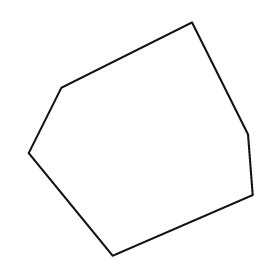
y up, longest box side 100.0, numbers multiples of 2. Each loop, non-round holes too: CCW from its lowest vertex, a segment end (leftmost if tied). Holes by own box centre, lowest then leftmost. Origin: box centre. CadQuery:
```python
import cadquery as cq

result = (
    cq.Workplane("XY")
    .moveTo(-12.0, -50.0)
    .lineTo(48.0, -24.0)
    .lineTo(46.0, 2.0)
    .lineTo(22.0, 50.0)
    .lineTo(-34.0, 22.0)
    .lineTo(-48.0, -6.0)
    .close()
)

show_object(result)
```